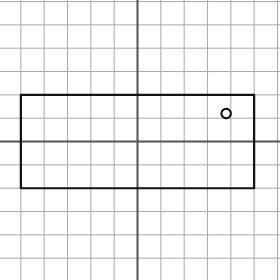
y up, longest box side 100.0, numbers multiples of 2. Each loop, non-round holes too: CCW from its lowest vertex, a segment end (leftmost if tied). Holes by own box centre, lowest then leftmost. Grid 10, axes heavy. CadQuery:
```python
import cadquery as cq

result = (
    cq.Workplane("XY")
    .moveTo(-50.0, -20.0)
    .lineTo(50.0, -20.0)
    .lineTo(50.0, 20.0)
    .lineTo(-50.0, 20.0)
    .close()
    .moveTo(38.0, 12.0)
    .circle(2.0)
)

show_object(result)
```